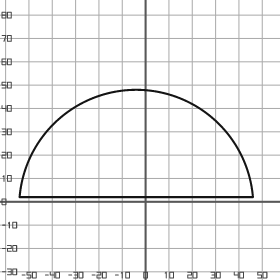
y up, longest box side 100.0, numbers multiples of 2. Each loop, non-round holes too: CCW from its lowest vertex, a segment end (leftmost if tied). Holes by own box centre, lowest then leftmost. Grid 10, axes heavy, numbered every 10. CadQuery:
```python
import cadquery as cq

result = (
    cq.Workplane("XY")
    .moveTo(-54.0, 2.0)
    .lineTo(46.0, 2.0)
    .threePointArc((-4.0, 48.0), (-54.0, 2.0))
    .close()
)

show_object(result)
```